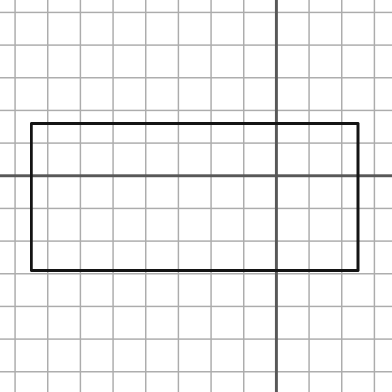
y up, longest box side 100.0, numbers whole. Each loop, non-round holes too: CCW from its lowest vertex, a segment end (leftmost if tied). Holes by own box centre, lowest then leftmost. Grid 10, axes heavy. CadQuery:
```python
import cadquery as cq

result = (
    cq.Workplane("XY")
    .moveTo(-75.0, -29.0)
    .lineTo(25.0, -29.0)
    .lineTo(25.0, 16.0)
    .lineTo(-75.0, 16.0)
    .close()
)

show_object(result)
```